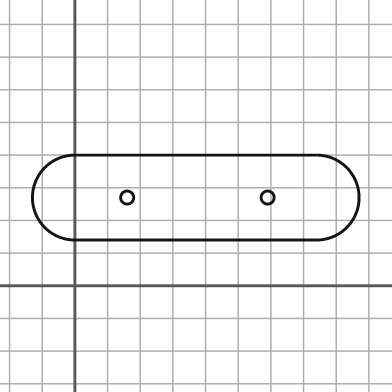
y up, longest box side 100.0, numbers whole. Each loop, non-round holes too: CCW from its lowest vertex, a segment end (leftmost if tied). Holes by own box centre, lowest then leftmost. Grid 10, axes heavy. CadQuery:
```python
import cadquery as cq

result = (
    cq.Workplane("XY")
    .moveTo(0.0, 14.0)
    .lineTo(74.0, 14.0)
    .threePointArc((87.0, 27.0), (74.0, 40.0))
    .lineTo(0.0, 40.0)
    .threePointArc((-13.0, 27.0), (0.0, 14.0))
    .close()
    .moveTo(16.0, 27.0)
    .circle(2.0)
    .moveTo(59.0, 27.0)
    .circle(2.0)
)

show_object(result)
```